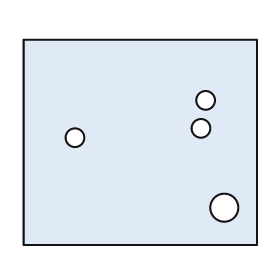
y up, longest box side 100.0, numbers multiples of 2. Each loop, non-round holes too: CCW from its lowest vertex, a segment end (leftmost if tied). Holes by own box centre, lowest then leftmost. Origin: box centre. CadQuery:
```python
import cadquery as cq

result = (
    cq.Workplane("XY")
    .moveTo(-50.0, -44.0)
    .lineTo(50.0, -44.0)
    .lineTo(50.0, 44.0)
    .lineTo(-50.0, 44.0)
    .close()
    .moveTo(36.0, -28.0)
    .circle(6.0)
    .moveTo(-28.0, 2.0)
    .circle(4.0)
    .moveTo(26.0, 6.0)
    .circle(4.0)
    .moveTo(28.0, 18.0)
    .circle(4.0)
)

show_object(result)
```